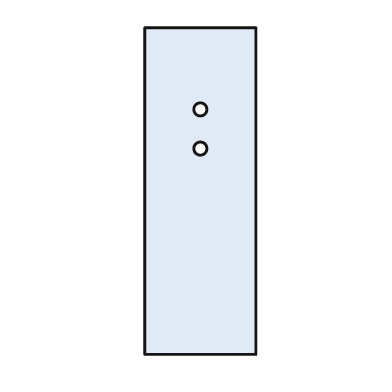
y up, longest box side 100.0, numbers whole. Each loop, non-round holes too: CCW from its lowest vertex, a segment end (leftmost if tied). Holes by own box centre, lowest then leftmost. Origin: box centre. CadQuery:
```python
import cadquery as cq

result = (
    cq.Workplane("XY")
    .moveTo(-17.0, -50.0)
    .lineTo(17.0, -50.0)
    .lineTo(17.0, 50.0)
    .lineTo(-17.0, 50.0)
    .close()
    .moveTo(0.0, 13.0)
    .circle(2.0)
    .moveTo(0.0, 25.0)
    .circle(2.0)
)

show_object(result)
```